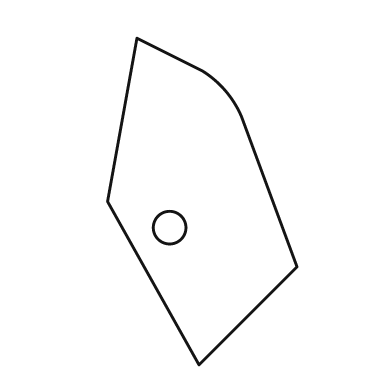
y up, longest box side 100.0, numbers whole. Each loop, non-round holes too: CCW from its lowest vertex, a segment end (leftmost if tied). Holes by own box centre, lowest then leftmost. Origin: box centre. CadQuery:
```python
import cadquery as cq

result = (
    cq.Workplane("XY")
    .moveTo(-1.0, -50.0)
    .lineTo(29.0, -20.0)
    .lineTo(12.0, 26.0)
    .threePointArc((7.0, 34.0), (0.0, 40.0))
    .lineTo(-20.0, 50.0)
    .lineTo(-29.0, 0.0)
    .close()
    .moveTo(-10.0, -8.0)
    .circle(5.0)
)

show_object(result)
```